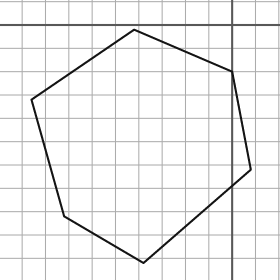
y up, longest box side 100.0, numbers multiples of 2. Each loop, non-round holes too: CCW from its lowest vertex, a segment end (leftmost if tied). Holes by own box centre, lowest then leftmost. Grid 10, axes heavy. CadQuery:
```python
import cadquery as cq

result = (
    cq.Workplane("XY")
    .moveTo(-38.0, -102.0)
    .lineTo(8.0, -62.0)
    .lineTo(0.0, -20.0)
    .lineTo(-42.0, -2.0)
    .lineTo(-86.0, -32.0)
    .lineTo(-72.0, -82.0)
    .close()
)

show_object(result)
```